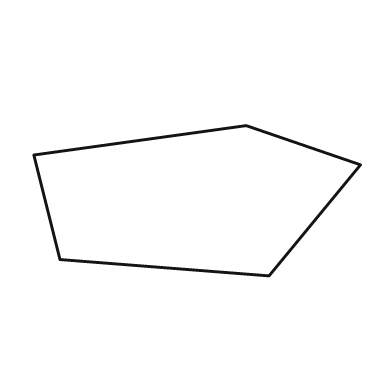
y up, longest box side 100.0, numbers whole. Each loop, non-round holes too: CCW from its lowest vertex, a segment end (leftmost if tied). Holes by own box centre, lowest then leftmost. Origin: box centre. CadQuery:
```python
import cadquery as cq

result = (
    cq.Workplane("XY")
    .moveTo(22.0, -23.0)
    .lineTo(50.0, 11.0)
    .lineTo(15.0, 23.0)
    .lineTo(-50.0, 14.0)
    .lineTo(-42.0, -18.0)
    .close()
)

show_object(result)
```